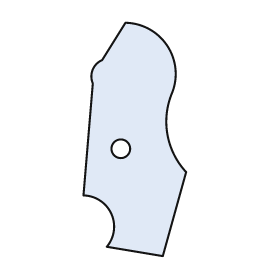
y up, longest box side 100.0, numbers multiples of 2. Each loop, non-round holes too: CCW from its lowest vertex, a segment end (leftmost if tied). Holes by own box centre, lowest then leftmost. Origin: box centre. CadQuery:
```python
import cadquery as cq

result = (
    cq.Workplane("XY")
    .moveTo(12.0, -50.0)
    .lineTo(22.0, -14.0)
    .threePointArc((14.0, 2.0), (16.0, 20.0))
    .threePointArc((14.0, 40.0), (-4.0, 50.0))
    .lineTo(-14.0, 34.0)
    .threePointArc((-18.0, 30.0), (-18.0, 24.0))
    .lineTo(-22.0, -24.0)
    .threePointArc((-10.0, -32.0), (-12.0, -46.0))
    .close()
    .moveTo(-6.0, -4.0)
    .circle(4.0)
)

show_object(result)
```